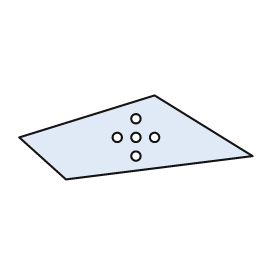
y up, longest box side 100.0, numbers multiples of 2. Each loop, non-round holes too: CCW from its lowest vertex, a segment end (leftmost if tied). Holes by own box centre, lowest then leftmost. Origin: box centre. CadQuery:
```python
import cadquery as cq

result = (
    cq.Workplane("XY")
    .moveTo(-30.0, -18.0)
    .lineTo(50.0, -8.0)
    .lineTo(8.0, 18.0)
    .lineTo(-50.0, 0.0)
    .close()
    .moveTo(0.0, -8.0)
    .circle(2.0)
    .moveTo(-8.0, 0.0)
    .circle(2.0)
    .moveTo(0.0, 0.0)
    .circle(2.0)
    .moveTo(8.0, 0.0)
    .circle(2.0)
    .moveTo(0.0, 8.0)
    .circle(2.0)
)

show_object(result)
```